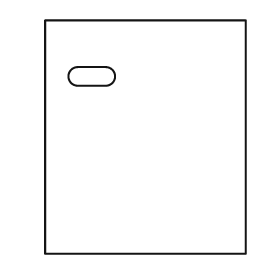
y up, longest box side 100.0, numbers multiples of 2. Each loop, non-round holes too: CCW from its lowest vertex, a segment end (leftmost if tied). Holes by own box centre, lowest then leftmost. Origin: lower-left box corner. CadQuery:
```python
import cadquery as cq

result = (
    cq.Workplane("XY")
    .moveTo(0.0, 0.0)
    .lineTo(86.0, 0.0)
    .lineTo(86.0, 100.0)
    .lineTo(0.0, 100.0)
    .close()
    .moveTo(14.0, 72.0)
    .lineTo(26.0, 72.0)
    .threePointArc((30.0, 76.0), (26.0, 80.0))
    .lineTo(14.0, 80.0)
    .threePointArc((10.0, 76.0), (14.0, 72.0))
    .close()
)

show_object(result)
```